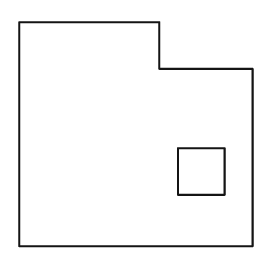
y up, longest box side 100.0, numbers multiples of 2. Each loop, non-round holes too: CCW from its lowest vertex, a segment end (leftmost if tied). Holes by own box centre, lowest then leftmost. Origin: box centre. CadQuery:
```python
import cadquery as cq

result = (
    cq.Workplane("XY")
    .moveTo(-50.0, -48.0)
    .lineTo(50.0, -48.0)
    .lineTo(50.0, 28.0)
    .lineTo(10.0, 28.0)
    .lineTo(10.0, 48.0)
    .lineTo(-50.0, 48.0)
    .close()
    .moveTo(18.0, -26.0)
    .lineTo(38.0, -26.0)
    .lineTo(38.0, -6.0)
    .lineTo(18.0, -6.0)
    .close()
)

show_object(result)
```